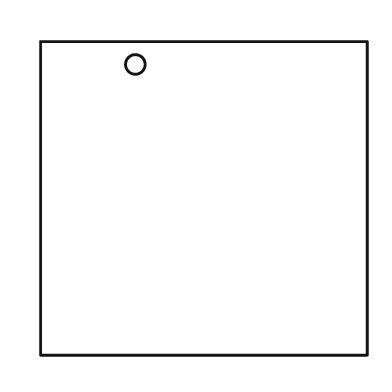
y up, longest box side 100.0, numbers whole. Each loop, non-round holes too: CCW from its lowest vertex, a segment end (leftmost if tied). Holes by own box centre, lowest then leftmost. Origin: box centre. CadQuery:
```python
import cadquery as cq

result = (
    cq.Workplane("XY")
    .moveTo(-50.0, -48.0)
    .lineTo(50.0, -48.0)
    .lineTo(50.0, 48.0)
    .lineTo(-50.0, 48.0)
    .close()
    .moveTo(-21.0, 41.0)
    .circle(3.0)
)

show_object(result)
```